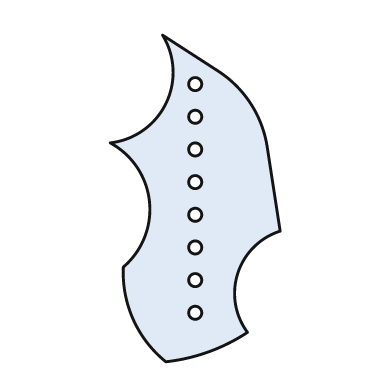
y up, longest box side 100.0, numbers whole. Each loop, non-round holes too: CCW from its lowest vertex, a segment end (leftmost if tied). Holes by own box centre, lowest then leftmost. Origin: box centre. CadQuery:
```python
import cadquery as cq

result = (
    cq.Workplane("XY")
    .moveTo(-9.0, -50.0)
    .threePointArc((4.0, -47.0), (16.0, -41.0))
    .threePointArc((13.0, -23.0), (26.0, -10.0))
    .lineTo(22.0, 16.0)
    .threePointArc((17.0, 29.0), (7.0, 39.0))
    .lineTo(-10.0, 50.0)
    .threePointArc((-9.0, 29.0), (-26.0, 17.0))
    .threePointArc((-14.0, -1.0), (-22.0, -21.0))
    .threePointArc((-19.0, -37.0), (-9.0, -50.0))
    .close()
    .moveTo(0.0, -35.0)
    .circle(2.0)
    .moveTo(0.0, -25.0)
    .circle(2.0)
    .moveTo(0.0, -15.0)
    .circle(2.0)
    .moveTo(0.0, -5.0)
    .circle(2.0)
    .moveTo(0.0, 5.0)
    .circle(2.0)
    .moveTo(0.0, 15.0)
    .circle(2.0)
    .moveTo(0.0, 25.0)
    .circle(2.0)
    .moveTo(0.0, 35.0)
    .circle(2.0)
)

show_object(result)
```